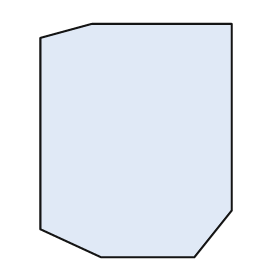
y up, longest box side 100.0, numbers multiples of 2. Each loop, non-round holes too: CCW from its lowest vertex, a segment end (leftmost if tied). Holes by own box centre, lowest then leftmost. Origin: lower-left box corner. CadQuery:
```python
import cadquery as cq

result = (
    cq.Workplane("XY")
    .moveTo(26.0, 0.0)
    .lineTo(66.0, 0.0)
    .lineTo(82.0, 20.0)
    .lineTo(82.0, 100.0)
    .lineTo(22.0, 100.0)
    .lineTo(0.0, 94.0)
    .lineTo(0.0, 12.0)
    .close()
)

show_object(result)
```